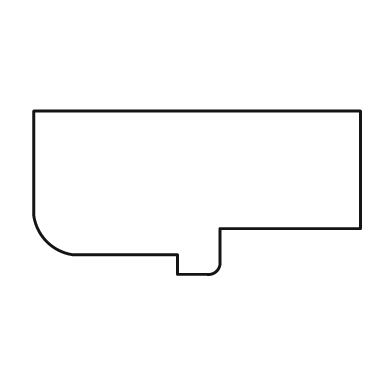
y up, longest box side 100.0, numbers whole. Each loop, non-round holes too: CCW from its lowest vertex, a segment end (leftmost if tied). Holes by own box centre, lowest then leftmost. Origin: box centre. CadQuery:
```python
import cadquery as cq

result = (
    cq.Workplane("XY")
    .moveTo(-6.0, -25.0)
    .lineTo(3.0, -25.0)
    .threePointArc((6.0, -24.0), (7.0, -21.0))
    .lineTo(7.0, -11.0)
    .lineTo(50.0, -11.0)
    .lineTo(50.0, 25.0)
    .lineTo(-50.0, 25.0)
    .lineTo(-50.0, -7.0)
    .threePointArc((-46.0, -15.0), (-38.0, -19.0))
    .lineTo(-6.0, -19.0)
    .close()
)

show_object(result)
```